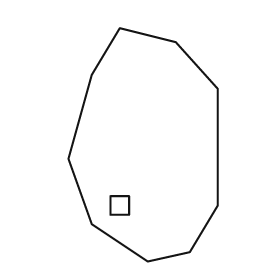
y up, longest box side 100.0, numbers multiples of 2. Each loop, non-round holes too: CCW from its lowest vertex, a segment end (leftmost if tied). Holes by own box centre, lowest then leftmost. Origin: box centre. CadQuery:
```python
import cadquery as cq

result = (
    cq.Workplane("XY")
    .moveTo(2.0, -50.0)
    .lineTo(20.0, -46.0)
    .lineTo(32.0, -26.0)
    .lineTo(32.0, 24.0)
    .lineTo(14.0, 44.0)
    .lineTo(-10.0, 50.0)
    .lineTo(-22.0, 30.0)
    .lineTo(-32.0, -6.0)
    .lineTo(-22.0, -34.0)
    .close()
    .moveTo(-14.0, -30.0)
    .lineTo(-6.0, -30.0)
    .lineTo(-6.0, -22.0)
    .lineTo(-14.0, -22.0)
    .close()
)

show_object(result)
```